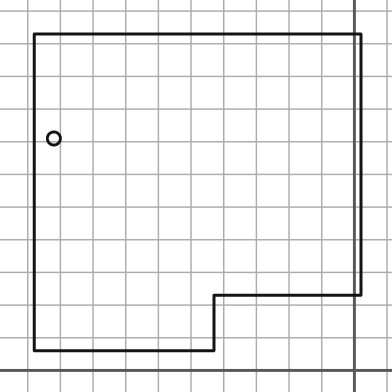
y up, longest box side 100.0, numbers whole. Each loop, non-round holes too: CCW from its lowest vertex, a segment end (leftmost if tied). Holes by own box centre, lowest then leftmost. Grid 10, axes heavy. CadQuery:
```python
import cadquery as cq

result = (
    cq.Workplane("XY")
    .moveTo(-98.0, 6.0)
    .lineTo(-43.0, 6.0)
    .lineTo(-43.0, 23.0)
    .lineTo(2.0, 23.0)
    .lineTo(2.0, 103.0)
    .lineTo(-98.0, 103.0)
    .close()
    .moveTo(-92.0, 71.0)
    .circle(2.0)
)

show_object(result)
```